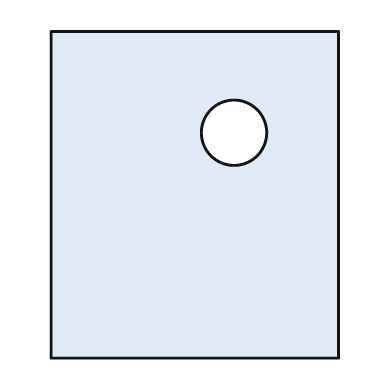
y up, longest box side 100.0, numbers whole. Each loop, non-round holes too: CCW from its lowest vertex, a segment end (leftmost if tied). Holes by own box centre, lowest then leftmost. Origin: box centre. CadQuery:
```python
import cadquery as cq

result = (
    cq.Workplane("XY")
    .moveTo(-44.0, -50.0)
    .lineTo(44.0, -50.0)
    .lineTo(44.0, 50.0)
    .lineTo(-44.0, 50.0)
    .close()
    .moveTo(12.0, 19.0)
    .circle(10.0)
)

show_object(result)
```